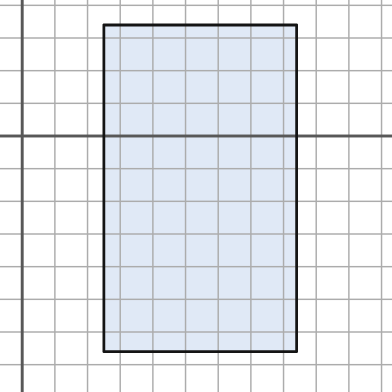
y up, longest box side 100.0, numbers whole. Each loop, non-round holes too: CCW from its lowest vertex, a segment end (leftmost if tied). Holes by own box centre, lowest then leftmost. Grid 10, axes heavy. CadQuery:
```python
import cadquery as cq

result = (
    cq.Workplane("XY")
    .moveTo(25.0, -66.0)
    .lineTo(84.0, -66.0)
    .lineTo(84.0, 34.0)
    .lineTo(25.0, 34.0)
    .close()
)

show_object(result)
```